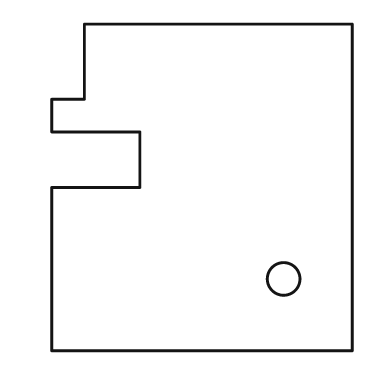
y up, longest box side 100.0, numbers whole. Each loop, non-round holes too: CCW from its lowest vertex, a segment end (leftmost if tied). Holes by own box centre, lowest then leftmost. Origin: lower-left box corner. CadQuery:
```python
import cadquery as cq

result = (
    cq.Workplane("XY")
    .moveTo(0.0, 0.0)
    .lineTo(92.0, 0.0)
    .lineTo(92.0, 100.0)
    .lineTo(10.0, 100.0)
    .lineTo(10.0, 77.0)
    .lineTo(0.0, 77.0)
    .lineTo(0.0, 67.0)
    .lineTo(27.0, 67.0)
    .lineTo(27.0, 50.0)
    .lineTo(0.0, 50.0)
    .close()
    .moveTo(71.0, 22.0)
    .circle(5.0)
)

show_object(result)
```